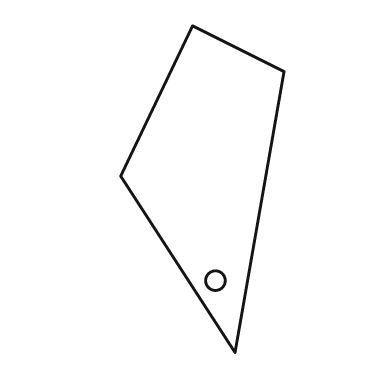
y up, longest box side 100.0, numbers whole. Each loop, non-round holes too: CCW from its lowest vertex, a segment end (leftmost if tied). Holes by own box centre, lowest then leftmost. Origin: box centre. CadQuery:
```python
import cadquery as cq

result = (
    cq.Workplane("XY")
    .moveTo(10.0, -50.0)
    .lineTo(25.0, 36.0)
    .lineTo(-3.0, 50.0)
    .lineTo(-25.0, 4.0)
    .close()
    .moveTo(4.0, -28.0)
    .circle(3.0)
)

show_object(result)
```